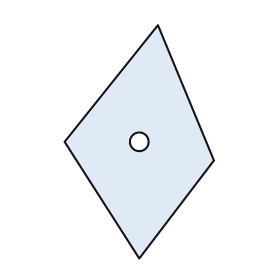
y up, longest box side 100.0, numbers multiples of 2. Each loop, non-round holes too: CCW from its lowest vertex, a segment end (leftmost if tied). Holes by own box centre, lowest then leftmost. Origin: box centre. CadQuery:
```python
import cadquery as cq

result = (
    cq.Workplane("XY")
    .moveTo(0.0, -50.0)
    .lineTo(32.0, -8.0)
    .lineTo(8.0, 50.0)
    .lineTo(-32.0, 0.0)
    .close()
    .moveTo(0.0, 0.0)
    .circle(4.0)
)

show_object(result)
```